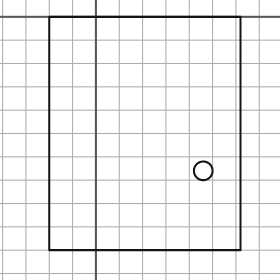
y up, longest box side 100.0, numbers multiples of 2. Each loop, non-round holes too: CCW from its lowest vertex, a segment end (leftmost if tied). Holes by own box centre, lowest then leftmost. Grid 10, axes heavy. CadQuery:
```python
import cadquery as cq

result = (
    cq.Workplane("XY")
    .moveTo(-20.0, -100.0)
    .lineTo(62.0, -100.0)
    .lineTo(62.0, 0.0)
    .lineTo(-20.0, 0.0)
    .close()
    .moveTo(46.0, -66.0)
    .circle(4.0)
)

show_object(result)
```